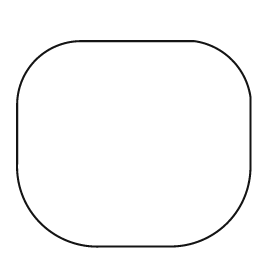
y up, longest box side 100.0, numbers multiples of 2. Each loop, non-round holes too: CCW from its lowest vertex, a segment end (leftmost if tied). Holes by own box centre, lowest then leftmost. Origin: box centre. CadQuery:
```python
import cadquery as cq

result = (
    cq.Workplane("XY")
    .moveTo(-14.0, -44.0)
    .lineTo(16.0, -44.0)
    .threePointArc((40.0, -34.0), (50.0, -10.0))
    .lineTo(50.0, 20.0)
    .threePointArc((42.0, 36.0), (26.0, 44.0))
    .lineTo(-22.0, 44.0)
    .threePointArc((-42.0, 36.0), (-50.0, 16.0))
    .lineTo(-50.0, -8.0)
    .threePointArc((-40.0, -34.0), (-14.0, -44.0))
    .close()
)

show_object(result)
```